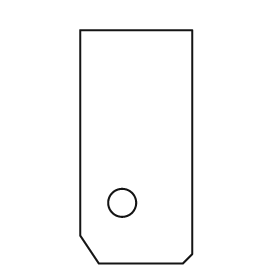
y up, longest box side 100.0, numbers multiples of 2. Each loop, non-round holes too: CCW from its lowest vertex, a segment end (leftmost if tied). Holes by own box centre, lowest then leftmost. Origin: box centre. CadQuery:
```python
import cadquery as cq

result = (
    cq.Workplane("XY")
    .moveTo(-16.0, -50.0)
    .lineTo(20.0, -50.0)
    .lineTo(24.0, -46.0)
    .lineTo(24.0, 50.0)
    .lineTo(-24.0, 50.0)
    .lineTo(-24.0, -38.0)
    .close()
    .moveTo(-6.0, -24.0)
    .circle(6.0)
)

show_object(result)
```